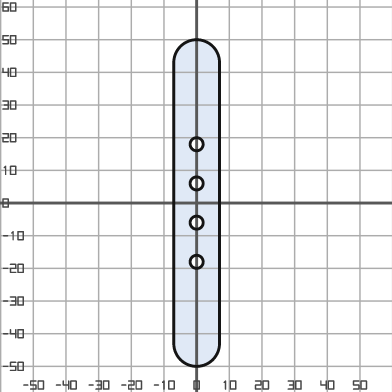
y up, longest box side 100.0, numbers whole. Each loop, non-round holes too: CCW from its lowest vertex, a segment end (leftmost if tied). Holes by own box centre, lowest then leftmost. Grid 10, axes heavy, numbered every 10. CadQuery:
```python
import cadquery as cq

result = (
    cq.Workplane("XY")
    .moveTo(-7.0, -43.0)
    .threePointArc((0.0, -50.0), (7.0, -43.0))
    .lineTo(7.0, 43.0)
    .threePointArc((0.0, 50.0), (-7.0, 43.0))
    .close()
    .moveTo(0.0, -18.0)
    .circle(2.0)
    .moveTo(0.0, -6.0)
    .circle(2.0)
    .moveTo(0.0, 6.0)
    .circle(2.0)
    .moveTo(0.0, 18.0)
    .circle(2.0)
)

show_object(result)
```